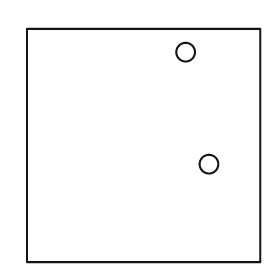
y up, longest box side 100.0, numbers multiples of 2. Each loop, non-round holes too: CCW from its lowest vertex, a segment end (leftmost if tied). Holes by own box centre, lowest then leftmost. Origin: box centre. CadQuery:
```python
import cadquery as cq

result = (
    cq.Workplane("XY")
    .moveTo(-50.0, -50.0)
    .lineTo(50.0, -50.0)
    .lineTo(50.0, 50.0)
    .lineTo(-50.0, 50.0)
    .close()
    .moveTo(28.0, -8.0)
    .circle(4.0)
    .moveTo(18.0, 40.0)
    .circle(4.0)
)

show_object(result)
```